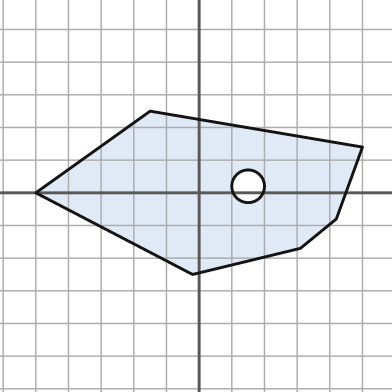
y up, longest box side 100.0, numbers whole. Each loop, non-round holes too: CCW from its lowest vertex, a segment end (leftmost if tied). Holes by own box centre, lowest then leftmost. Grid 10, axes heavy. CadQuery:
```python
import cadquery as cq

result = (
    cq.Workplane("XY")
    .moveTo(-2.0, -25.0)
    .lineTo(31.0, -17.0)
    .lineTo(42.0, -8.0)
    .lineTo(50.0, 14.0)
    .lineTo(-15.0, 25.0)
    .lineTo(-50.0, 0.0)
    .close()
    .moveTo(15.0, 2.0)
    .circle(5.0)
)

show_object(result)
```